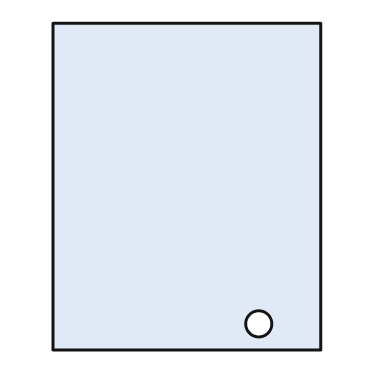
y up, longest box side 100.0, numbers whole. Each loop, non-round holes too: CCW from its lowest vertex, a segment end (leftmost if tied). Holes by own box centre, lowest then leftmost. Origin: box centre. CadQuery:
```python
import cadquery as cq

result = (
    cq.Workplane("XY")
    .moveTo(-41.0, -50.0)
    .lineTo(41.0, -50.0)
    .lineTo(41.0, 50.0)
    .lineTo(-41.0, 50.0)
    .close()
    .moveTo(22.0, -42.0)
    .circle(4.0)
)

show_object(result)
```